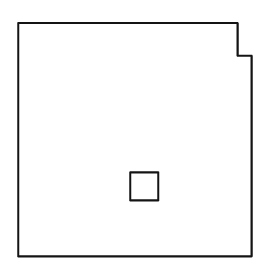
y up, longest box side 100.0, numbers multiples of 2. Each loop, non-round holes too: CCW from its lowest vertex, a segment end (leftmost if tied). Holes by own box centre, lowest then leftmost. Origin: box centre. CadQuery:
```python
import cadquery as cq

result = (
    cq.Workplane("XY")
    .moveTo(-50.0, -50.0)
    .lineTo(50.0, -50.0)
    .lineTo(50.0, 36.0)
    .lineTo(44.0, 36.0)
    .lineTo(44.0, 50.0)
    .lineTo(-50.0, 50.0)
    .close()
    .moveTo(-2.0, -26.0)
    .lineTo(10.0, -26.0)
    .lineTo(10.0, -14.0)
    .lineTo(-2.0, -14.0)
    .close()
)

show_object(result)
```